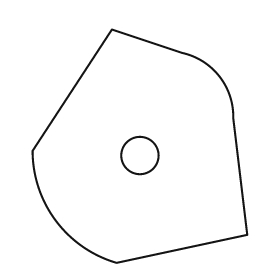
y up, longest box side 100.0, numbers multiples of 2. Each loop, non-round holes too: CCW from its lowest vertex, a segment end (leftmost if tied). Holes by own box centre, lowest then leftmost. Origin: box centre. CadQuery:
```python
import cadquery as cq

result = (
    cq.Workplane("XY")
    .moveTo(-10.0, -50.0)
    .lineTo(46.0, -38.0)
    .lineTo(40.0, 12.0)
    .threePointArc((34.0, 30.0), (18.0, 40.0))
    .lineTo(-12.0, 50.0)
    .lineTo(-46.0, -2.0)
    .threePointArc((-36.0, -32.0), (-10.0, -50.0))
    .close()
    .moveTo(0.0, -4.0)
    .circle(8.0)
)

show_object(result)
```